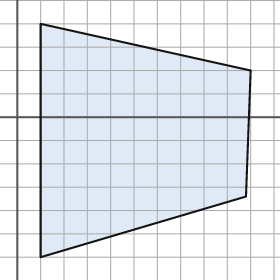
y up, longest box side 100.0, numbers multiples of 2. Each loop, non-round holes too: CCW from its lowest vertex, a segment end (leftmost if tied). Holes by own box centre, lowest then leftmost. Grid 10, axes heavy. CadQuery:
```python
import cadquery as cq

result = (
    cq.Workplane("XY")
    .moveTo(10.0, -60.0)
    .lineTo(98.0, -34.0)
    .lineTo(100.0, 20.0)
    .lineTo(10.0, 40.0)
    .close()
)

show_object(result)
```